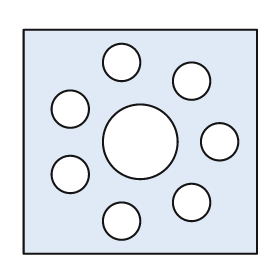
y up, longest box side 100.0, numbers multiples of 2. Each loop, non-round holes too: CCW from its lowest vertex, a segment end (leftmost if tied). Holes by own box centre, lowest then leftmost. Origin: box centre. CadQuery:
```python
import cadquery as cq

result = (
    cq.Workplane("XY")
    .moveTo(-50.0, -48.0)
    .lineTo(50.0, -48.0)
    .lineTo(50.0, 48.0)
    .lineTo(-50.0, 48.0)
    .close()
    .moveTo(-8.0, -34.0)
    .circle(8.0)
    .moveTo(22.0, -26.0)
    .circle(8.0)
    .moveTo(-30.0, -14.0)
    .circle(8.0)
    .moveTo(0.0, 0.0)
    .circle(16.0)
    .moveTo(34.0, 0.0)
    .circle(8.0)
    .moveTo(-30.0, 14.0)
    .circle(8.0)
    .moveTo(22.0, 26.0)
    .circle(8.0)
    .moveTo(-8.0, 34.0)
    .circle(8.0)
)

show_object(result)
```